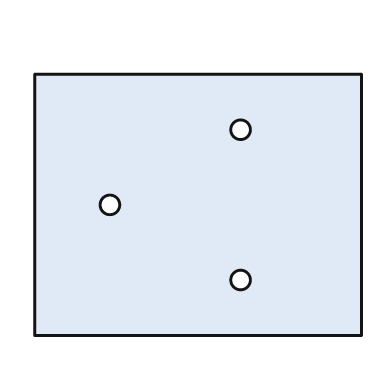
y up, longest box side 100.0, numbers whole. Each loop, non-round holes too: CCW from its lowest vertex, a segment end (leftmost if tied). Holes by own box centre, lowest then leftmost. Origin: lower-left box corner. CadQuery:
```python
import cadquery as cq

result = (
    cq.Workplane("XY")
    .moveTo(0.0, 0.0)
    .lineTo(100.0, 0.0)
    .lineTo(100.0, 80.0)
    .lineTo(0.0, 80.0)
    .close()
    .moveTo(63.0, 17.0)
    .circle(3.0)
    .moveTo(23.0, 40.0)
    .circle(3.0)
    .moveTo(63.0, 63.0)
    .circle(3.0)
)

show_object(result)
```